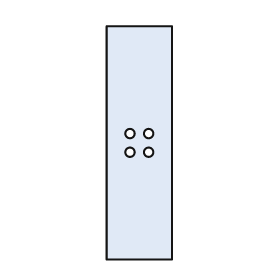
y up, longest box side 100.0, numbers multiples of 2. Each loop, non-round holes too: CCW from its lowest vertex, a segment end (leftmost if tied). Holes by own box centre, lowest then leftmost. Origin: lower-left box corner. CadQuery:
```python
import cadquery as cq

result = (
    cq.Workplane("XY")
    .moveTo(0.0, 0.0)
    .lineTo(28.0, 0.0)
    .lineTo(28.0, 100.0)
    .lineTo(0.0, 100.0)
    .close()
    .moveTo(10.0, 46.0)
    .circle(2.0)
    .moveTo(18.0, 46.0)
    .circle(2.0)
    .moveTo(10.0, 54.0)
    .circle(2.0)
    .moveTo(18.0, 54.0)
    .circle(2.0)
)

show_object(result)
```